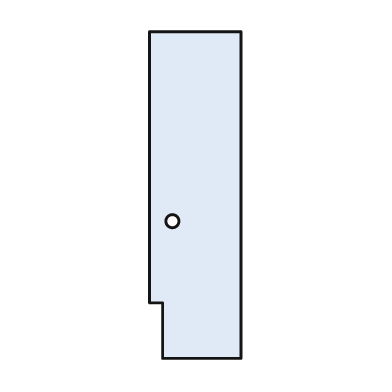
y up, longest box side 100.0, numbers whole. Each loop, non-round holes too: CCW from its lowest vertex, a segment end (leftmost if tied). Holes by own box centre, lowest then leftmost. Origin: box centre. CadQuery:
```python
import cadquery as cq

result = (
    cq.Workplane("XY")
    .moveTo(-10.0, -50.0)
    .lineTo(14.0, -50.0)
    .lineTo(14.0, 50.0)
    .lineTo(-14.0, 50.0)
    .lineTo(-14.0, -33.0)
    .lineTo(-10.0, -33.0)
    .close()
    .moveTo(-7.0, -8.0)
    .circle(2.0)
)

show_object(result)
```